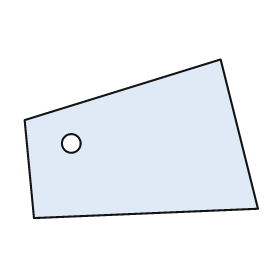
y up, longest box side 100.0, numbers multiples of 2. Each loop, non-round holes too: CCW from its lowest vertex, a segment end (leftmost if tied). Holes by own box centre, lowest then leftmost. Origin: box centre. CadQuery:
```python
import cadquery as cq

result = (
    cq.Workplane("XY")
    .moveTo(-46.0, -34.0)
    .lineTo(50.0, -30.0)
    .lineTo(34.0, 34.0)
    .lineTo(-50.0, 8.0)
    .close()
    .moveTo(-30.0, -2.0)
    .circle(4.0)
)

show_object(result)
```